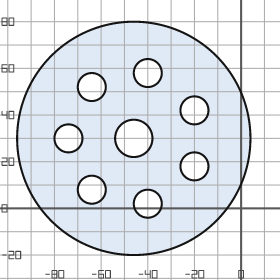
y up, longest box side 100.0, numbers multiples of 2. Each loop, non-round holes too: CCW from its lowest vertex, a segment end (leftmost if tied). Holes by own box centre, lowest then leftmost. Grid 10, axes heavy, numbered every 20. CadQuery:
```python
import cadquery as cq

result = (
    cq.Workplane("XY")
    .moveTo(-46.0, 30.0)
    .circle(50.0)
    .moveTo(-40.0, 2.0)
    .circle(6.0)
    .moveTo(-64.0, 8.0)
    .circle(6.0)
    .moveTo(-20.0, 18.0)
    .circle(6.0)
    .moveTo(-74.0, 30.0)
    .circle(6.0)
    .moveTo(-46.0, 30.0)
    .circle(8.0)
    .moveTo(-20.0, 42.0)
    .circle(6.0)
    .moveTo(-64.0, 52.0)
    .circle(6.0)
    .moveTo(-40.0, 58.0)
    .circle(6.0)
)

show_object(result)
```